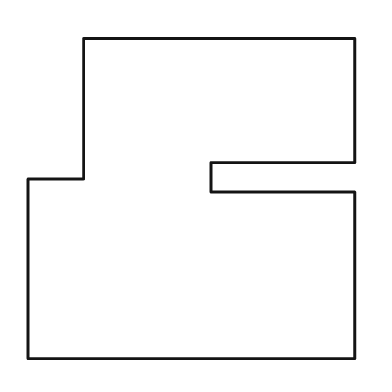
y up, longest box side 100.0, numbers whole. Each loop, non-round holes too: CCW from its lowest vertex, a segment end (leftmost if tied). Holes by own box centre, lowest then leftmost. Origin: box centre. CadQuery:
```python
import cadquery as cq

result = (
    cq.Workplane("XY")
    .moveTo(-50.0, -49.0)
    .lineTo(50.0, -49.0)
    .lineTo(50.0, 2.0)
    .lineTo(6.0, 2.0)
    .lineTo(6.0, 11.0)
    .lineTo(50.0, 11.0)
    .lineTo(50.0, 49.0)
    .lineTo(-33.0, 49.0)
    .lineTo(-33.0, 6.0)
    .lineTo(-50.0, 6.0)
    .close()
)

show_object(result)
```